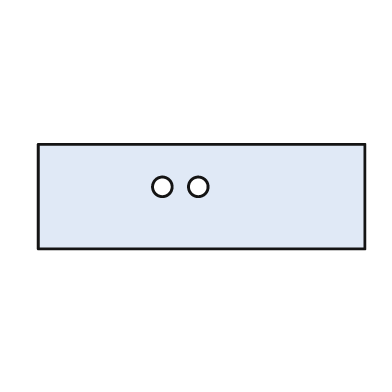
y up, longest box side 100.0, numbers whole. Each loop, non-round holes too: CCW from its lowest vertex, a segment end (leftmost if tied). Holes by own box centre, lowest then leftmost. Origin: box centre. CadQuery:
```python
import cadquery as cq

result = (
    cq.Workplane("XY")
    .moveTo(-50.0, -16.0)
    .lineTo(50.0, -16.0)
    .lineTo(50.0, 16.0)
    .lineTo(-50.0, 16.0)
    .close()
    .moveTo(-12.0, 3.0)
    .circle(3.0)
    .moveTo(-1.0, 3.0)
    .circle(3.0)
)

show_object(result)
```